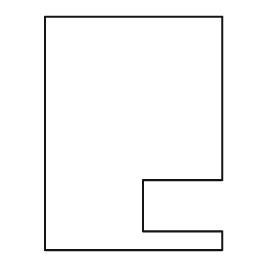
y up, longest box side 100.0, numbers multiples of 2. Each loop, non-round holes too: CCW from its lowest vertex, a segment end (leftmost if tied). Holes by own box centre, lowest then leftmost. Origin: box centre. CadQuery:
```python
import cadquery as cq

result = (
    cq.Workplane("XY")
    .moveTo(-38.0, -50.0)
    .lineTo(38.0, -50.0)
    .lineTo(38.0, -42.0)
    .lineTo(4.0, -42.0)
    .lineTo(4.0, -20.0)
    .lineTo(38.0, -20.0)
    .lineTo(38.0, 50.0)
    .lineTo(-38.0, 50.0)
    .close()
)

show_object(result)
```